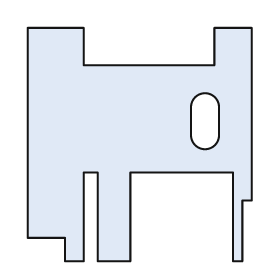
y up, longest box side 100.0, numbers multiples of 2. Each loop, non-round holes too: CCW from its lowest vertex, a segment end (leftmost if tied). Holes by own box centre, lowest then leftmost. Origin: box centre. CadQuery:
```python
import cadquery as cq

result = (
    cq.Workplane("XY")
    .moveTo(-32.0, -50.0)
    .lineTo(-24.0, -50.0)
    .lineTo(-24.0, -12.0)
    .lineTo(-18.0, -12.0)
    .lineTo(-18.0, -50.0)
    .lineTo(-4.0, -50.0)
    .lineTo(-4.0, -12.0)
    .lineTo(40.0, -12.0)
    .lineTo(40.0, -50.0)
    .lineTo(44.0, -50.0)
    .lineTo(44.0, -24.0)
    .lineTo(48.0, -24.0)
    .lineTo(48.0, 50.0)
    .lineTo(32.0, 50.0)
    .lineTo(32.0, 34.0)
    .lineTo(-24.0, 34.0)
    .lineTo(-24.0, 50.0)
    .lineTo(-48.0, 50.0)
    .lineTo(-48.0, -40.0)
    .lineTo(-32.0, -40.0)
    .close()
    .moveTo(22.0, 4.0)
    .threePointArc((28.0, -2.0), (34.0, 4.0))
    .lineTo(34.0, 16.0)
    .threePointArc((28.0, 22.0), (22.0, 16.0))
    .close()
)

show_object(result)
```